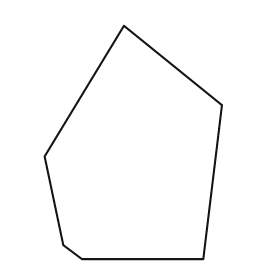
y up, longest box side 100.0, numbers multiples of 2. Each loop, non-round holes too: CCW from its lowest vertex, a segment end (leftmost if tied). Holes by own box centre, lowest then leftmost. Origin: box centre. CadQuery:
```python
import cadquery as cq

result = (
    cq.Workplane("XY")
    .moveTo(-22.0, -50.0)
    .lineTo(30.0, -50.0)
    .lineTo(38.0, 16.0)
    .lineTo(-4.0, 50.0)
    .lineTo(-38.0, -6.0)
    .lineTo(-30.0, -44.0)
    .close()
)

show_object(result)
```